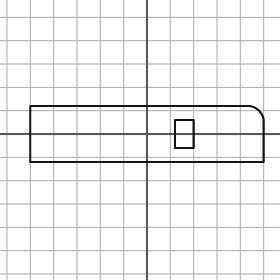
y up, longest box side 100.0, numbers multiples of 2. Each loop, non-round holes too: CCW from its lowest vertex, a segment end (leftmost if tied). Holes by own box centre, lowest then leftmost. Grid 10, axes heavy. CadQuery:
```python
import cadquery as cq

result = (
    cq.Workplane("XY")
    .moveTo(-50.0, -12.0)
    .lineTo(50.0, -12.0)
    .lineTo(50.0, 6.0)
    .threePointArc((48.0, 10.0), (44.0, 12.0))
    .lineTo(-50.0, 12.0)
    .close()
    .moveTo(12.0, -6.0)
    .lineTo(20.0, -6.0)
    .lineTo(20.0, 6.0)
    .lineTo(12.0, 6.0)
    .close()
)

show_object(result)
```